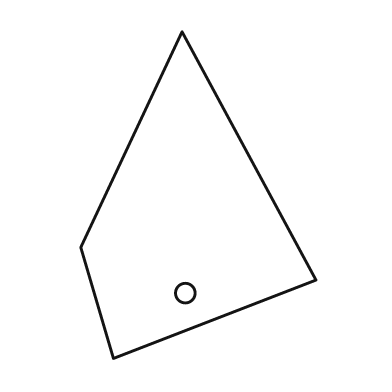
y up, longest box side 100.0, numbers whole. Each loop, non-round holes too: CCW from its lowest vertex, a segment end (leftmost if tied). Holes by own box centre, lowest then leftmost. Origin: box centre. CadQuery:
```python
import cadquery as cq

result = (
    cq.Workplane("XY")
    .moveTo(-26.0, -50.0)
    .lineTo(36.0, -26.0)
    .lineTo(-5.0, 50.0)
    .lineTo(-36.0, -16.0)
    .close()
    .moveTo(-4.0, -30.0)
    .circle(3.0)
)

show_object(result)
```